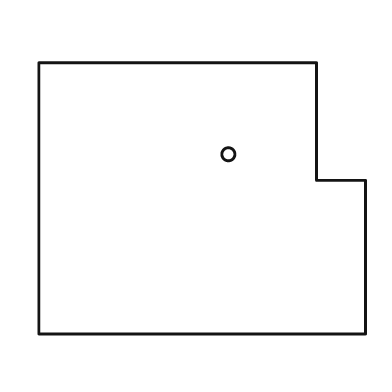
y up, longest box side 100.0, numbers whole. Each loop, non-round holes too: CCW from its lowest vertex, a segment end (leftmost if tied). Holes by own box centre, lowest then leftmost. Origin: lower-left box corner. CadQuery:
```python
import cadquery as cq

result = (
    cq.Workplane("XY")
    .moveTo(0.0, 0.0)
    .lineTo(100.0, 0.0)
    .lineTo(100.0, 47.0)
    .lineTo(85.0, 47.0)
    .lineTo(85.0, 83.0)
    .lineTo(0.0, 83.0)
    .close()
    .moveTo(58.0, 55.0)
    .circle(2.0)
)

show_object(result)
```